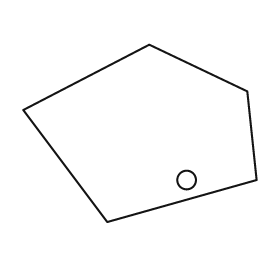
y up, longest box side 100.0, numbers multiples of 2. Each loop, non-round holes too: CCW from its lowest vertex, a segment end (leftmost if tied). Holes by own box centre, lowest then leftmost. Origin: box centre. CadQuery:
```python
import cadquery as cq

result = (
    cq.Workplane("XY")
    .moveTo(-14.0, -38.0)
    .lineTo(50.0, -20.0)
    .lineTo(46.0, 18.0)
    .lineTo(4.0, 38.0)
    .lineTo(-50.0, 10.0)
    .close()
    .moveTo(20.0, -20.0)
    .circle(4.0)
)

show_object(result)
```